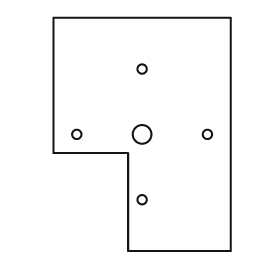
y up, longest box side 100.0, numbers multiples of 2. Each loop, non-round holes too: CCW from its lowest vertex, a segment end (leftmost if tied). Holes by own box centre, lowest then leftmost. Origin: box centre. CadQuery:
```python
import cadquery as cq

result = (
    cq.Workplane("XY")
    .moveTo(-6.0, -50.0)
    .lineTo(38.0, -50.0)
    .lineTo(38.0, 50.0)
    .lineTo(-38.0, 50.0)
    .lineTo(-38.0, -8.0)
    .lineTo(-6.0, -8.0)
    .close()
    .moveTo(0.0, -28.0)
    .circle(2.0)
    .moveTo(-28.0, 0.0)
    .circle(2.0)
    .moveTo(0.0, 0.0)
    .circle(4.0)
    .moveTo(28.0, 0.0)
    .circle(2.0)
    .moveTo(0.0, 28.0)
    .circle(2.0)
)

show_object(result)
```